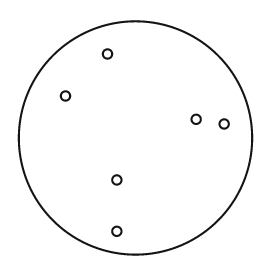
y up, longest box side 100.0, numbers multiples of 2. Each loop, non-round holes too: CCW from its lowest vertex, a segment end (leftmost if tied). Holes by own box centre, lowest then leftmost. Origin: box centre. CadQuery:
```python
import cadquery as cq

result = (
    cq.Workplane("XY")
    .moveTo(0.0, 0.0)
    .circle(50.0)
    .moveTo(-8.0, -40.0)
    .circle(2.0)
    .moveTo(-8.0, -18.0)
    .circle(2.0)
    .moveTo(38.0, 6.0)
    .circle(2.0)
    .moveTo(26.0, 8.0)
    .circle(2.0)
    .moveTo(-30.0, 18.0)
    .circle(2.0)
    .moveTo(-12.0, 36.0)
    .circle(2.0)
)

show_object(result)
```